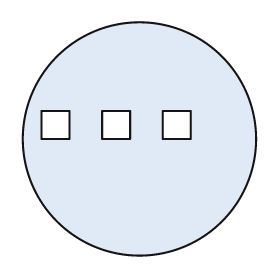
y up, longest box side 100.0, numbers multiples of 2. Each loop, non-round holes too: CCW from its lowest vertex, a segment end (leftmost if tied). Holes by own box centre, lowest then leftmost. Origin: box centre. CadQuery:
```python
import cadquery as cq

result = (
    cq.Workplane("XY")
    .moveTo(0.0, 0.0)
    .circle(50.0)
    .moveTo(-42.0, 0.0)
    .lineTo(-30.0, 0.0)
    .lineTo(-30.0, 12.0)
    .lineTo(-42.0, 12.0)
    .close()
    .moveTo(-16.0, 0.0)
    .lineTo(-4.0, 0.0)
    .lineTo(-4.0, 12.0)
    .lineTo(-16.0, 12.0)
    .close()
    .moveTo(10.0, 0.0)
    .lineTo(22.0, 0.0)
    .lineTo(22.0, 12.0)
    .lineTo(10.0, 12.0)
    .close()
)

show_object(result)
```